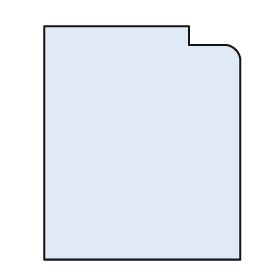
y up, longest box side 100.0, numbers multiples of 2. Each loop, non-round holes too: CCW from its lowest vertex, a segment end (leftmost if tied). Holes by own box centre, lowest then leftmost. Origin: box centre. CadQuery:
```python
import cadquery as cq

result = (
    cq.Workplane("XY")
    .moveTo(-42.0, -50.0)
    .lineTo(42.0, -50.0)
    .lineTo(42.0, 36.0)
    .threePointArc((40.0, 40.0), (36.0, 42.0))
    .lineTo(20.0, 42.0)
    .lineTo(20.0, 50.0)
    .lineTo(-42.0, 50.0)
    .close()
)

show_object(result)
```